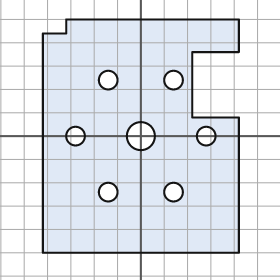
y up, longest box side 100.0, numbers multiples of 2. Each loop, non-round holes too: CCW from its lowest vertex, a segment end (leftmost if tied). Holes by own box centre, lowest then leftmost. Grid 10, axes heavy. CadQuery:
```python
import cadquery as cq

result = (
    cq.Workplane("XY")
    .moveTo(-42.0, -50.0)
    .lineTo(42.0, -50.0)
    .lineTo(42.0, 8.0)
    .lineTo(22.0, 8.0)
    .lineTo(22.0, 36.0)
    .lineTo(42.0, 36.0)
    .lineTo(42.0, 50.0)
    .lineTo(-32.0, 50.0)
    .lineTo(-32.0, 44.0)
    .lineTo(-42.0, 44.0)
    .close()
    .moveTo(-14.0, -24.0)
    .circle(4.0)
    .moveTo(14.0, -24.0)
    .circle(4.0)
    .moveTo(-28.0, 0.0)
    .circle(4.0)
    .moveTo(0.0, 0.0)
    .circle(6.0)
    .moveTo(28.0, 0.0)
    .circle(4.0)
    .moveTo(-14.0, 24.0)
    .circle(4.0)
    .moveTo(14.0, 24.0)
    .circle(4.0)
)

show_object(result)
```